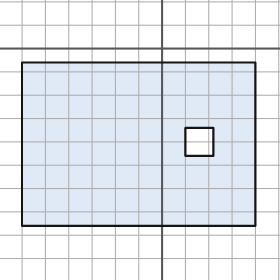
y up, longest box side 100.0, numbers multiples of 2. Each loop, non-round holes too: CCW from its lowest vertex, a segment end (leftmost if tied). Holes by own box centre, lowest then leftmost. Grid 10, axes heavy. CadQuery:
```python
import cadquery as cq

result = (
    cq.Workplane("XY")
    .moveTo(-60.0, -76.0)
    .lineTo(40.0, -76.0)
    .lineTo(40.0, -6.0)
    .lineTo(-60.0, -6.0)
    .close()
    .moveTo(10.0, -46.0)
    .lineTo(22.0, -46.0)
    .lineTo(22.0, -34.0)
    .lineTo(10.0, -34.0)
    .close()
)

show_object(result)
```